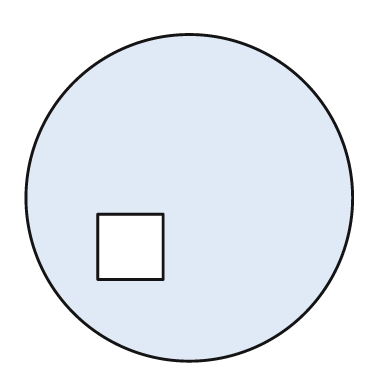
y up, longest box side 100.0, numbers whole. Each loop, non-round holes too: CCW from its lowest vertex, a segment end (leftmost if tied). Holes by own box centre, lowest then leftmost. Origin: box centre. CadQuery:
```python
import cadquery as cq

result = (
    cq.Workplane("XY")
    .moveTo(0.0, 0.0)
    .circle(50.0)
    .moveTo(-28.0, -25.0)
    .lineTo(-8.0, -25.0)
    .lineTo(-8.0, -5.0)
    .lineTo(-28.0, -5.0)
    .close()
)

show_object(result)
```